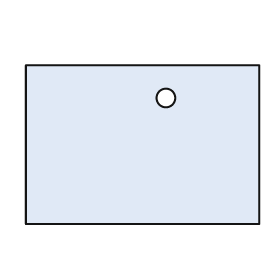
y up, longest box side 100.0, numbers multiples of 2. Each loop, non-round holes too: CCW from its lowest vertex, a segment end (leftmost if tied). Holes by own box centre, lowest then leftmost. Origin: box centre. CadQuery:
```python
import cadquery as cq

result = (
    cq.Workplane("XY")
    .moveTo(-50.0, -34.0)
    .lineTo(50.0, -34.0)
    .lineTo(50.0, 34.0)
    .lineTo(-50.0, 34.0)
    .close()
    .moveTo(10.0, 20.0)
    .circle(4.0)
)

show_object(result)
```